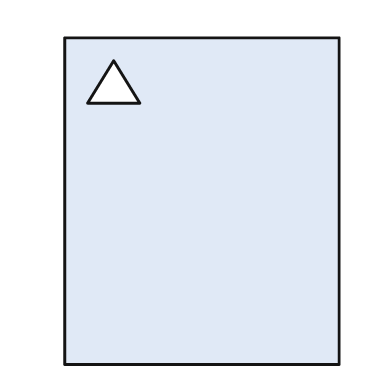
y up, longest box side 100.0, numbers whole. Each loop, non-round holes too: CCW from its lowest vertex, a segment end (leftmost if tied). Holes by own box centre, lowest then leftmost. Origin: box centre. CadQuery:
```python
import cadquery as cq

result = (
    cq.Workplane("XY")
    .moveTo(-42.0, -50.0)
    .lineTo(42.0, -50.0)
    .lineTo(42.0, 50.0)
    .lineTo(-42.0, 50.0)
    .close()
    .moveTo(-35.0, 30.0)
    .lineTo(-19.0, 30.0)
    .lineTo(-27.0, 43.0)
    .close()
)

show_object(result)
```